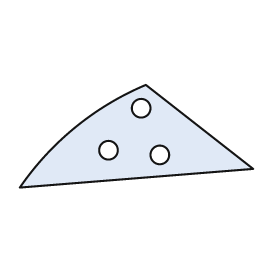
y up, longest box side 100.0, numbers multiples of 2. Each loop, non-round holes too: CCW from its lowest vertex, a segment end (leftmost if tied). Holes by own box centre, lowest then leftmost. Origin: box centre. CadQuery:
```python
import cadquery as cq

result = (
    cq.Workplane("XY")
    .moveTo(-50.0, -22.0)
    .lineTo(50.0, -14.0)
    .lineTo(4.0, 22.0)
    .threePointArc((-26.0, 4.0), (-50.0, -22.0))
    .close()
    .moveTo(10.0, -8.0)
    .circle(4.0)
    .moveTo(-12.0, -6.0)
    .circle(4.0)
    .moveTo(2.0, 12.0)
    .circle(4.0)
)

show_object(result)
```